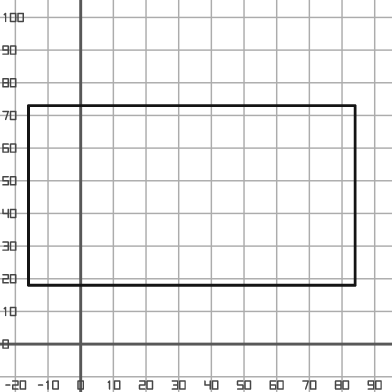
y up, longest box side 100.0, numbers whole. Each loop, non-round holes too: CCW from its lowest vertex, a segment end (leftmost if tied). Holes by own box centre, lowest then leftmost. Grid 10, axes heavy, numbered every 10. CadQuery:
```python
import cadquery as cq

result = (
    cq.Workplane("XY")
    .moveTo(-16.0, 18.0)
    .lineTo(84.0, 18.0)
    .lineTo(84.0, 73.0)
    .lineTo(-16.0, 73.0)
    .close()
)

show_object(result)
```